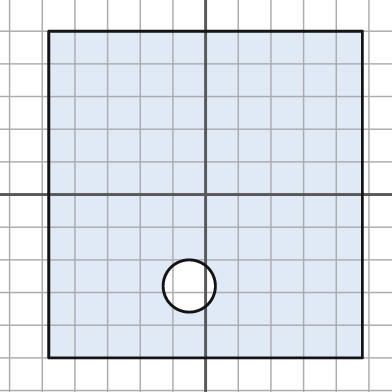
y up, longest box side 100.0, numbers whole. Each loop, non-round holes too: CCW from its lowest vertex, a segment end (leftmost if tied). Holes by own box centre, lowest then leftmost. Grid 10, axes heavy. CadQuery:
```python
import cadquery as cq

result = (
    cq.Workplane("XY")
    .moveTo(-48.0, -50.0)
    .lineTo(48.0, -50.0)
    .lineTo(48.0, 50.0)
    .lineTo(-48.0, 50.0)
    .close()
    .moveTo(-5.0, -28.0)
    .circle(8.0)
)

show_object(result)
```